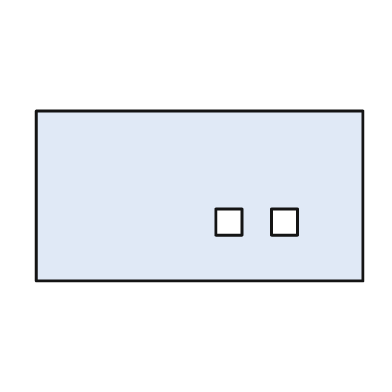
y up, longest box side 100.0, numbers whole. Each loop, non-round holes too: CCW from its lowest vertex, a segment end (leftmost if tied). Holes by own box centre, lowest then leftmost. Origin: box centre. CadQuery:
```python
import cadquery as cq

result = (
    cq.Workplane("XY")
    .moveTo(-50.0, -26.0)
    .lineTo(50.0, -26.0)
    .lineTo(50.0, 26.0)
    .lineTo(-50.0, 26.0)
    .close()
    .moveTo(5.0, -12.0)
    .lineTo(13.0, -12.0)
    .lineTo(13.0, -4.0)
    .lineTo(5.0, -4.0)
    .close()
    .moveTo(22.0, -12.0)
    .lineTo(30.0, -12.0)
    .lineTo(30.0, -4.0)
    .lineTo(22.0, -4.0)
    .close()
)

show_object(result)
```